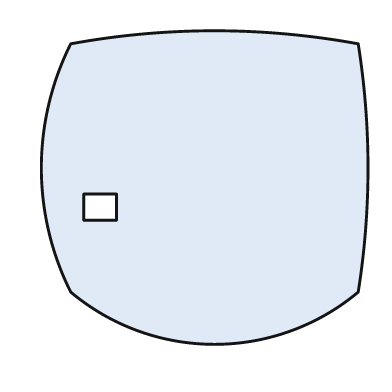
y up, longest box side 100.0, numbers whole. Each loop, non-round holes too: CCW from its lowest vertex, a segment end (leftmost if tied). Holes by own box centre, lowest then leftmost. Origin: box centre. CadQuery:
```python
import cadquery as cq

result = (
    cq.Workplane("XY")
    .moveTo(-41.0, -32.0)
    .threePointArc((3.0, -48.0), (47.0, -32.0))
    .threePointArc((50.0, 6.0), (47.0, 44.0))
    .threePointArc((3.0, 48.0), (-41.0, 44.0))
    .threePointArc((-50.0, 6.0), (-41.0, -32.0))
    .close()
    .moveTo(-37.0, -10.0)
    .lineTo(-27.0, -10.0)
    .lineTo(-27.0, -2.0)
    .lineTo(-37.0, -2.0)
    .close()
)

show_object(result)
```